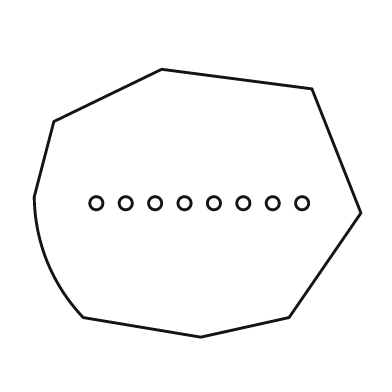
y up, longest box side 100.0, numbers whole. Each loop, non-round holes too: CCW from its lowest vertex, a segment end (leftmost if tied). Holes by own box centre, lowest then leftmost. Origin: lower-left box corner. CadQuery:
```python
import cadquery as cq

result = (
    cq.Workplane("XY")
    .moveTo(51.0, 0.0)
    .lineTo(78.0, 6.0)
    .lineTo(100.0, 38.0)
    .lineTo(85.0, 76.0)
    .lineTo(39.0, 82.0)
    .lineTo(6.0, 66.0)
    .lineTo(0.0, 43.0)
    .threePointArc((4.0, 23.0), (15.0, 6.0))
    .close()
    .moveTo(19.0, 41.0)
    .circle(2.0)
    .moveTo(28.0, 41.0)
    .circle(2.0)
    .moveTo(37.0, 41.0)
    .circle(2.0)
    .moveTo(46.0, 41.0)
    .circle(2.0)
    .moveTo(55.0, 41.0)
    .circle(2.0)
    .moveTo(64.0, 41.0)
    .circle(2.0)
    .moveTo(73.0, 41.0)
    .circle(2.0)
    .moveTo(82.0, 41.0)
    .circle(2.0)
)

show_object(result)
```